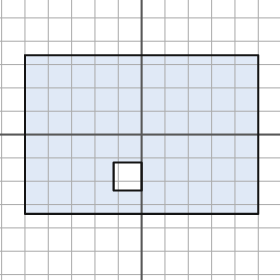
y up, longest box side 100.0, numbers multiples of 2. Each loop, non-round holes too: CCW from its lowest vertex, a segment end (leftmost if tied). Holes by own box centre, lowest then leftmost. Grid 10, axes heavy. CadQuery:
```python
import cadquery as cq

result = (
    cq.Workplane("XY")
    .moveTo(-50.0, -34.0)
    .lineTo(50.0, -34.0)
    .lineTo(50.0, 34.0)
    .lineTo(-50.0, 34.0)
    .close()
    .moveTo(-12.0, -24.0)
    .lineTo(0.0, -24.0)
    .lineTo(0.0, -12.0)
    .lineTo(-12.0, -12.0)
    .close()
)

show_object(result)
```